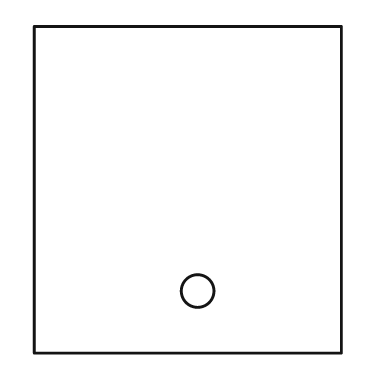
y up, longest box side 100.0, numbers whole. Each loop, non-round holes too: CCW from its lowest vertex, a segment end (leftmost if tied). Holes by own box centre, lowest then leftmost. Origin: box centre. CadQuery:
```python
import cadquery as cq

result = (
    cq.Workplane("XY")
    .moveTo(-47.0, -50.0)
    .lineTo(47.0, -50.0)
    .lineTo(47.0, 50.0)
    .lineTo(-47.0, 50.0)
    .close()
    .moveTo(3.0, -31.0)
    .circle(5.0)
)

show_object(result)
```